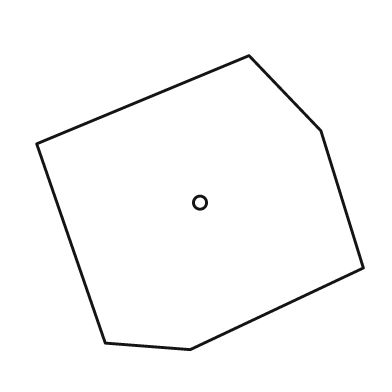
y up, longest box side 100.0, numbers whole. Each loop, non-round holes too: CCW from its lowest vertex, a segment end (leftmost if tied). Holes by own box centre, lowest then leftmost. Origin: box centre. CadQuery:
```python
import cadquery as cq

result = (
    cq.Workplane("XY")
    .moveTo(-3.0, -45.0)
    .lineTo(50.0, -20.0)
    .lineTo(37.0, 22.0)
    .lineTo(15.0, 45.0)
    .lineTo(-50.0, 18.0)
    .lineTo(-29.0, -43.0)
    .close()
    .moveTo(0.0, 0.0)
    .circle(2.0)
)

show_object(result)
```